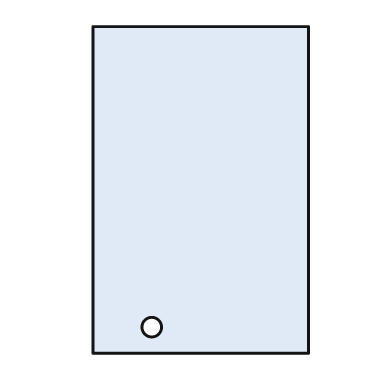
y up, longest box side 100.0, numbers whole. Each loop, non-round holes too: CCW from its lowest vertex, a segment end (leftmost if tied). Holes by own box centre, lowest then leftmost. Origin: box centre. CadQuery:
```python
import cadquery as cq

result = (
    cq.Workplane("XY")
    .moveTo(-33.0, -50.0)
    .lineTo(33.0, -50.0)
    .lineTo(33.0, 50.0)
    .lineTo(-33.0, 50.0)
    .close()
    .moveTo(-15.0, -42.0)
    .circle(3.0)
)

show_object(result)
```